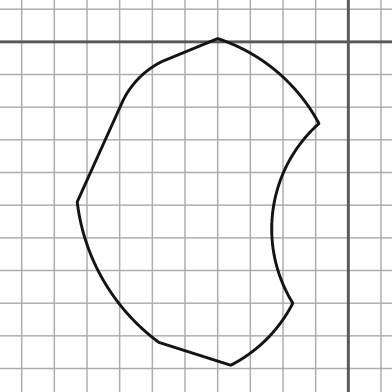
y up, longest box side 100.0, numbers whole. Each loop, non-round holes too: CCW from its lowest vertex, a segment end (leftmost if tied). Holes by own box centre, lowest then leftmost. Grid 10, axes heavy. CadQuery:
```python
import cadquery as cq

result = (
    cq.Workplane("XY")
    .moveTo(-36.0, -99.0)
    .threePointArc((-25.0, -91.0), (-17.0, -80.0))
    .threePointArc((-23.0, -51.0), (-9.0, -25.0))
    .threePointArc((-22.0, -9.0), (-40.0, 1.0))
    .lineTo(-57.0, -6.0)
    .threePointArc((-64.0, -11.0), (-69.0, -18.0))
    .lineTo(-83.0, -49.0)
    .threePointArc((-75.0, -73.0), (-58.0, -92.0))
    .close()
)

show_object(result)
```